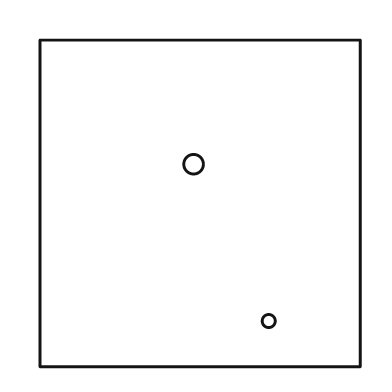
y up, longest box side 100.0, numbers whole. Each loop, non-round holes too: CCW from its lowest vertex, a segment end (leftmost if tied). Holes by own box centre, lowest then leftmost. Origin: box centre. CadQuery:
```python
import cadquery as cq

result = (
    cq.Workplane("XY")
    .moveTo(-49.0, -50.0)
    .lineTo(49.0, -50.0)
    .lineTo(49.0, 50.0)
    .lineTo(-49.0, 50.0)
    .close()
    .moveTo(21.0, -36.0)
    .circle(2.0)
    .moveTo(-2.0, 12.0)
    .circle(3.0)
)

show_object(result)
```